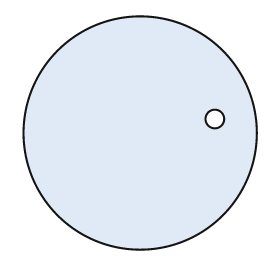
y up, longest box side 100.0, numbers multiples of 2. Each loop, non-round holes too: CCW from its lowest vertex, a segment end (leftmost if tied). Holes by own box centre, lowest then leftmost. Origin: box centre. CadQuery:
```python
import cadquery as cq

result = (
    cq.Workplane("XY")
    .moveTo(0.0, 0.0)
    .circle(50.0)
    .moveTo(32.0, 6.0)
    .circle(4.0)
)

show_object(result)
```